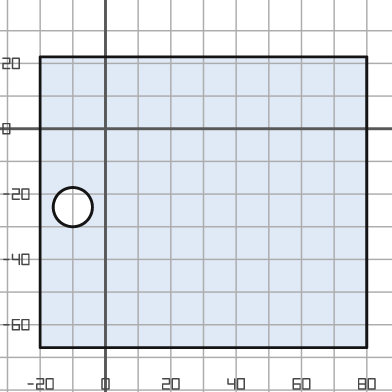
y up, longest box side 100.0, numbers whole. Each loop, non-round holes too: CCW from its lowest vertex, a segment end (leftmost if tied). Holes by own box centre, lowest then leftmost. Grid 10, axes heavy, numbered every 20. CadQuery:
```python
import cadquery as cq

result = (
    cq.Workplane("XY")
    .moveTo(-20.0, -67.0)
    .lineTo(80.0, -67.0)
    .lineTo(80.0, 22.0)
    .lineTo(-20.0, 22.0)
    .close()
    .moveTo(-10.0, -24.0)
    .circle(6.0)
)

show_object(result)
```